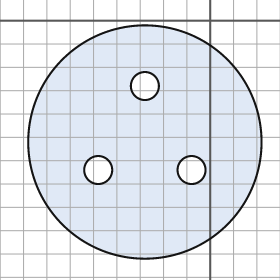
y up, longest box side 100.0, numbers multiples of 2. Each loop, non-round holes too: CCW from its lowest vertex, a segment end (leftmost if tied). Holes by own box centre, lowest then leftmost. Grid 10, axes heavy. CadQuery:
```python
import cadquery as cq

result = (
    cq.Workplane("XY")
    .moveTo(-28.0, -52.0)
    .circle(50.0)
    .moveTo(-48.0, -64.0)
    .circle(6.0)
    .moveTo(-8.0, -64.0)
    .circle(6.0)
    .moveTo(-28.0, -28.0)
    .circle(6.0)
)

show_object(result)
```